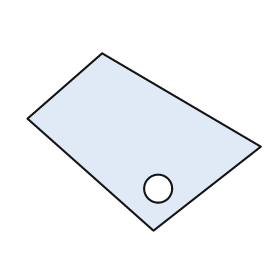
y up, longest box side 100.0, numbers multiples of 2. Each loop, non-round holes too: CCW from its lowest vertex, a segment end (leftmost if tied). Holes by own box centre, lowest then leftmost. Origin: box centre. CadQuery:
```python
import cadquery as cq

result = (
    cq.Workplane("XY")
    .moveTo(4.0, -38.0)
    .lineTo(50.0, -2.0)
    .lineTo(-18.0, 38.0)
    .lineTo(-50.0, 10.0)
    .close()
    .moveTo(6.0, -20.0)
    .circle(6.0)
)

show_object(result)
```